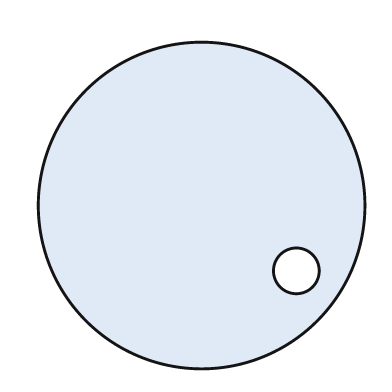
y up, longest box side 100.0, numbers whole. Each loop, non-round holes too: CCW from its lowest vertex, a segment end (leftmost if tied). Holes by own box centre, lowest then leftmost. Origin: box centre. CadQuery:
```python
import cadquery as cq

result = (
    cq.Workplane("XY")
    .moveTo(0.0, 0.0)
    .circle(50.0)
    .moveTo(29.0, -20.0)
    .circle(7.0)
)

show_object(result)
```